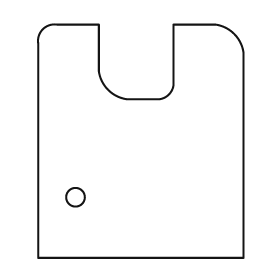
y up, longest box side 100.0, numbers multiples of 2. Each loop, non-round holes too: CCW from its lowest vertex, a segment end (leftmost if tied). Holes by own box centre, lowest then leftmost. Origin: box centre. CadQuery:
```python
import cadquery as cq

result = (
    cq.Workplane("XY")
    .moveTo(-44.0, -50.0)
    .lineTo(44.0, -50.0)
    .lineTo(44.0, 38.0)
    .threePointArc((40.0, 46.0), (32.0, 50.0))
    .lineTo(14.0, 50.0)
    .lineTo(14.0, 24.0)
    .threePointArc((12.0, 20.0), (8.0, 18.0))
    .lineTo(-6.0, 18.0)
    .threePointArc((-14.0, 22.0), (-18.0, 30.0))
    .lineTo(-18.0, 50.0)
    .lineTo(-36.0, 50.0)
    .threePointArc((-42.0, 48.0), (-44.0, 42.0))
    .close()
    .moveTo(-28.0, -24.0)
    .circle(4.0)
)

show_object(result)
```